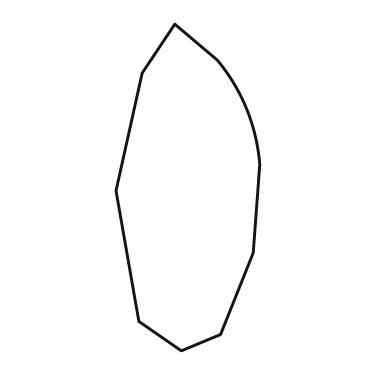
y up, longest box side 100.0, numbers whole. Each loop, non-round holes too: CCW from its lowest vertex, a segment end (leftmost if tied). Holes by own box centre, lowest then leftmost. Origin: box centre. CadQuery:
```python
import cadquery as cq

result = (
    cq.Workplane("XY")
    .moveTo(-2.0, -50.0)
    .lineTo(10.0, -45.0)
    .lineTo(20.0, -20.0)
    .lineTo(22.0, 7.0)
    .threePointArc((18.0, 24.0), (9.0, 39.0))
    .lineTo(-4.0, 50.0)
    .lineTo(-14.0, 35.0)
    .lineTo(-22.0, -1.0)
    .lineTo(-15.0, -41.0)
    .close()
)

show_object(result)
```